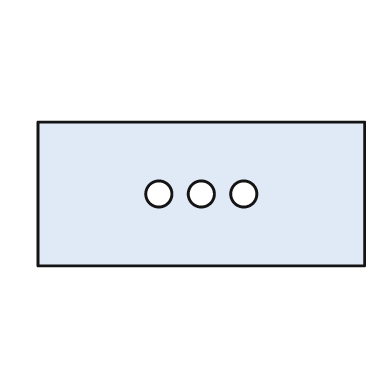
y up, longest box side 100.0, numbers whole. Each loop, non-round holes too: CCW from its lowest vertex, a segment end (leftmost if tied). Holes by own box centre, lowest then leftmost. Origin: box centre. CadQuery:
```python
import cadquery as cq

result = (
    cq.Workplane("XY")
    .moveTo(-50.0, -22.0)
    .lineTo(50.0, -22.0)
    .lineTo(50.0, 22.0)
    .lineTo(-50.0, 22.0)
    .close()
    .moveTo(-13.0, 0.0)
    .circle(4.0)
    .moveTo(0.0, 0.0)
    .circle(4.0)
    .moveTo(13.0, 0.0)
    .circle(4.0)
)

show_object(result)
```